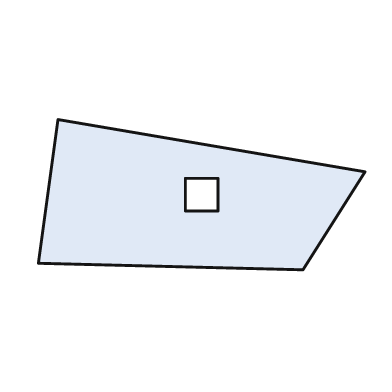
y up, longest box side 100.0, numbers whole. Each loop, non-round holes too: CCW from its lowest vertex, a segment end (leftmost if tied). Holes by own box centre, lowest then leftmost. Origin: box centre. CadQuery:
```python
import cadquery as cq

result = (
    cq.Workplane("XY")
    .moveTo(31.0, -23.0)
    .lineTo(50.0, 7.0)
    .lineTo(-44.0, 23.0)
    .lineTo(-50.0, -21.0)
    .close()
    .moveTo(-5.0, -5.0)
    .lineTo(5.0, -5.0)
    .lineTo(5.0, 5.0)
    .lineTo(-5.0, 5.0)
    .close()
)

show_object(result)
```